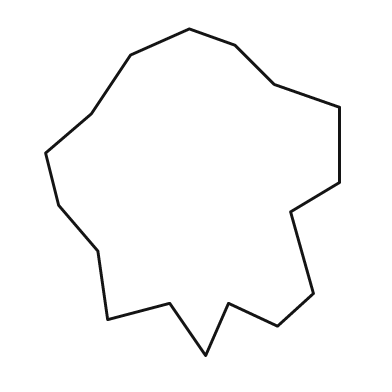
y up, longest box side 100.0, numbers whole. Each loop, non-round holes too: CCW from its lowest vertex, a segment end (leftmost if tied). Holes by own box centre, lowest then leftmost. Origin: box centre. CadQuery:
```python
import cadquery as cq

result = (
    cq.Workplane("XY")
    .moveTo(4.0, -50.0)
    .lineTo(11.0, -34.0)
    .lineTo(26.0, -41.0)
    .lineTo(37.0, -31.0)
    .lineTo(30.0, -6.0)
    .lineTo(45.0, 3.0)
    .lineTo(45.0, 26.0)
    .lineTo(25.0, 33.0)
    .lineTo(13.0, 45.0)
    .lineTo(-1.0, 50.0)
    .lineTo(-19.0, 42.0)
    .lineTo(-31.0, 24.0)
    .lineTo(-45.0, 12.0)
    .lineTo(-41.0, -4.0)
    .lineTo(-29.0, -18.0)
    .lineTo(-26.0, -39.0)
    .lineTo(-7.0, -34.0)
    .close()
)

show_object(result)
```